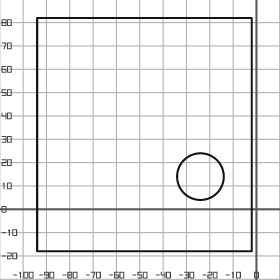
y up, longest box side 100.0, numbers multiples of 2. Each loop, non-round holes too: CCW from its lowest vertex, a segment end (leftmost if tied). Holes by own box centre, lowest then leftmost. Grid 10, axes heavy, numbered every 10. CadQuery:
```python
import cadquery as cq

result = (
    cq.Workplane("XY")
    .moveTo(-94.0, -18.0)
    .lineTo(-2.0, -18.0)
    .lineTo(-2.0, 82.0)
    .lineTo(-94.0, 82.0)
    .close()
    .moveTo(-24.0, 14.0)
    .circle(10.0)
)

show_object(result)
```